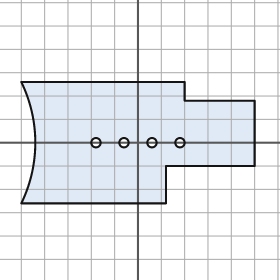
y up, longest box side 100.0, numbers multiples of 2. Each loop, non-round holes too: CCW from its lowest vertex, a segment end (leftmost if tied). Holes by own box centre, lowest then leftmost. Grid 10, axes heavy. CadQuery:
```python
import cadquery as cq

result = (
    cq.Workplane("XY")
    .moveTo(-50.0, -26.0)
    .lineTo(12.0, -26.0)
    .lineTo(12.0, -10.0)
    .lineTo(50.0, -10.0)
    .lineTo(50.0, 18.0)
    .lineTo(20.0, 18.0)
    .lineTo(20.0, 26.0)
    .lineTo(-50.0, 26.0)
    .threePointArc((-44.0, 0.0), (-50.0, -26.0))
    .close()
    .moveTo(-18.0, 0.0)
    .circle(2.0)
    .moveTo(-6.0, 0.0)
    .circle(2.0)
    .moveTo(6.0, 0.0)
    .circle(2.0)
    .moveTo(18.0, 0.0)
    .circle(2.0)
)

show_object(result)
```